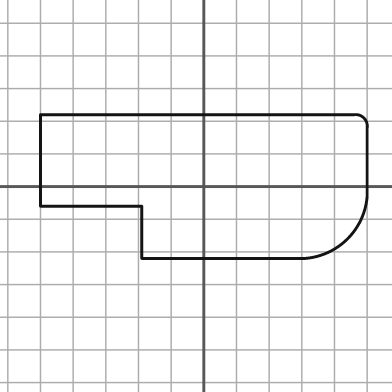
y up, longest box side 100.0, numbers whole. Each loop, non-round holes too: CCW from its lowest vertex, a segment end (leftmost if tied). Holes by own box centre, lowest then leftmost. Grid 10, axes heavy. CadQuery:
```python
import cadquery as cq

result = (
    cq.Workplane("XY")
    .moveTo(-19.0, -22.0)
    .lineTo(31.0, -22.0)
    .threePointArc((44.0, -16.0), (50.0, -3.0))
    .lineTo(50.0, 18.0)
    .threePointArc((49.0, 21.0), (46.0, 22.0))
    .lineTo(-50.0, 22.0)
    .lineTo(-50.0, -6.0)
    .lineTo(-19.0, -6.0)
    .close()
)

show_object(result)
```